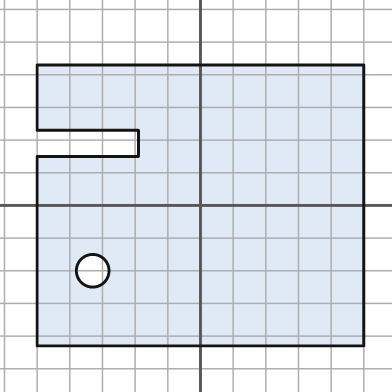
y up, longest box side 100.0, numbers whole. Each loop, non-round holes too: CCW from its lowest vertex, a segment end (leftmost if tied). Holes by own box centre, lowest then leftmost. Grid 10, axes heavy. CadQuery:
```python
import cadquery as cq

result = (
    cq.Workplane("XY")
    .moveTo(-50.0, -43.0)
    .lineTo(50.0, -43.0)
    .lineTo(50.0, 43.0)
    .lineTo(-50.0, 43.0)
    .lineTo(-50.0, 23.0)
    .lineTo(-19.0, 23.0)
    .lineTo(-19.0, 15.0)
    .lineTo(-50.0, 15.0)
    .close()
    .moveTo(-33.0, -20.0)
    .circle(5.0)
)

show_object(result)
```